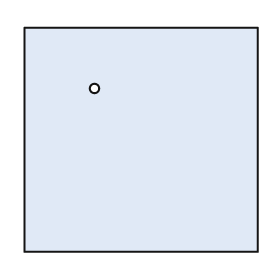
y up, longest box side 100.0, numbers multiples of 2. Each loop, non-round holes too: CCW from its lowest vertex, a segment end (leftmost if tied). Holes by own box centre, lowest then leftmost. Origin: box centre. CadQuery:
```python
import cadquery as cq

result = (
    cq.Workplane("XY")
    .moveTo(-50.0, -48.0)
    .lineTo(50.0, -48.0)
    .lineTo(50.0, 48.0)
    .lineTo(-50.0, 48.0)
    .close()
    .moveTo(-20.0, 22.0)
    .circle(2.0)
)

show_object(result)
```